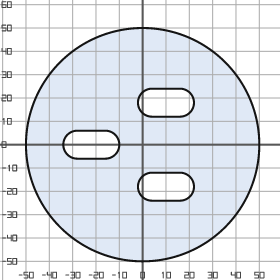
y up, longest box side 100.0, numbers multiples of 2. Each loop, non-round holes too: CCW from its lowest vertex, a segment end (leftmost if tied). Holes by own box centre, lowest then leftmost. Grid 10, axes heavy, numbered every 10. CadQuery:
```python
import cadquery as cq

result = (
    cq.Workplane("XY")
    .moveTo(0.0, 0.0)
    .circle(50.0)
    .moveTo(4.0, -24.0)
    .lineTo(16.0, -24.0)
    .threePointArc((22.0, -18.0), (16.0, -12.0))
    .lineTo(4.0, -12.0)
    .threePointArc((-2.0, -18.0), (4.0, -24.0))
    .close()
    .moveTo(-28.0, -6.0)
    .lineTo(-16.0, -6.0)
    .threePointArc((-10.0, 0.0), (-16.0, 6.0))
    .lineTo(-28.0, 6.0)
    .threePointArc((-34.0, 0.0), (-28.0, -6.0))
    .close()
    .moveTo(4.0, 12.0)
    .lineTo(16.0, 12.0)
    .threePointArc((22.0, 18.0), (16.0, 24.0))
    .lineTo(4.0, 24.0)
    .threePointArc((-2.0, 18.0), (4.0, 12.0))
    .close()
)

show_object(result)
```